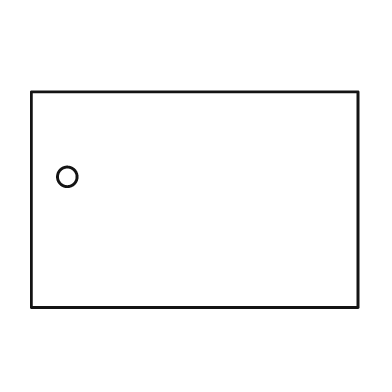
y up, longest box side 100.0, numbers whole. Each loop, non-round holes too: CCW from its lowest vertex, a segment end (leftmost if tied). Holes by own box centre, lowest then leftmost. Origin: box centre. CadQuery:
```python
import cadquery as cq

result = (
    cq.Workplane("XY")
    .moveTo(-50.0, -33.0)
    .lineTo(50.0, -33.0)
    .lineTo(50.0, 33.0)
    .lineTo(-50.0, 33.0)
    .close()
    .moveTo(-39.0, 7.0)
    .circle(3.0)
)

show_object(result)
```